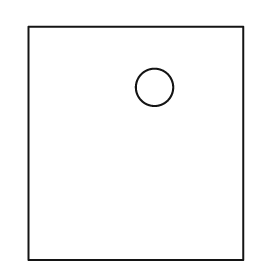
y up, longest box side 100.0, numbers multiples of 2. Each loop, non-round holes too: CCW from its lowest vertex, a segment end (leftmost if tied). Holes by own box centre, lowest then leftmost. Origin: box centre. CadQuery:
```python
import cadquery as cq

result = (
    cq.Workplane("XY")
    .moveTo(-46.0, -50.0)
    .lineTo(46.0, -50.0)
    .lineTo(46.0, 50.0)
    .lineTo(-46.0, 50.0)
    .close()
    .moveTo(8.0, 24.0)
    .circle(8.0)
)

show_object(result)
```